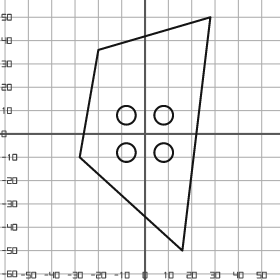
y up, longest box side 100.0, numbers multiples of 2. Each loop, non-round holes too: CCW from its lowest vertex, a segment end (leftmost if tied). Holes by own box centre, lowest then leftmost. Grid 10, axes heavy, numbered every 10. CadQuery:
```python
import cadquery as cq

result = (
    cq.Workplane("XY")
    .moveTo(16.0, -50.0)
    .lineTo(28.0, 50.0)
    .lineTo(-20.0, 36.0)
    .lineTo(-28.0, -10.0)
    .close()
    .moveTo(-8.0, -8.0)
    .circle(4.0)
    .moveTo(8.0, -8.0)
    .circle(4.0)
    .moveTo(-8.0, 8.0)
    .circle(4.0)
    .moveTo(8.0, 8.0)
    .circle(4.0)
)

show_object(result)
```